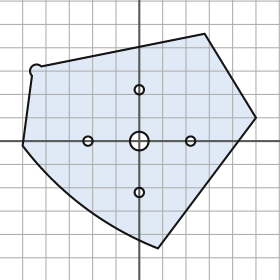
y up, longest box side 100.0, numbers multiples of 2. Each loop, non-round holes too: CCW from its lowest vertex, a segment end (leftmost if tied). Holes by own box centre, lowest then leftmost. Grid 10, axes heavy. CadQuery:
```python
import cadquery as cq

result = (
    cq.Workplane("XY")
    .moveTo(8.0, -46.0)
    .lineTo(50.0, 10.0)
    .lineTo(28.0, 46.0)
    .lineTo(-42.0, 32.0)
    .threePointArc((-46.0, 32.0), (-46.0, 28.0))
    .lineTo(-50.0, -2.0)
    .threePointArc((-24.0, -28.0), (8.0, -46.0))
    .close()
    .moveTo(0.0, -22.0)
    .circle(2.0)
    .moveTo(-22.0, 0.0)
    .circle(2.0)
    .moveTo(0.0, 0.0)
    .circle(4.0)
    .moveTo(22.0, 0.0)
    .circle(2.0)
    .moveTo(0.0, 22.0)
    .circle(2.0)
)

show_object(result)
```